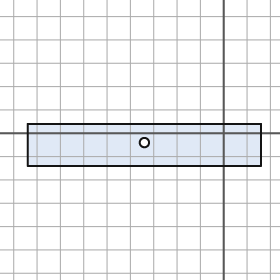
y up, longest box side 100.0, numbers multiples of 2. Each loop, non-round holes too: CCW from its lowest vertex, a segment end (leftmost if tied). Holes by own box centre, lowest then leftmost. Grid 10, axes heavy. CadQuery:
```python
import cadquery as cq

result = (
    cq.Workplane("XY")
    .moveTo(-84.0, -14.0)
    .lineTo(16.0, -14.0)
    .lineTo(16.0, 4.0)
    .lineTo(-84.0, 4.0)
    .close()
    .moveTo(-34.0, -4.0)
    .circle(2.0)
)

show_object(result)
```